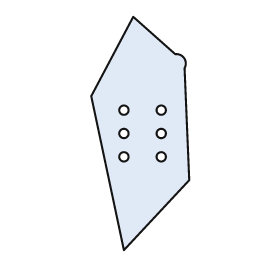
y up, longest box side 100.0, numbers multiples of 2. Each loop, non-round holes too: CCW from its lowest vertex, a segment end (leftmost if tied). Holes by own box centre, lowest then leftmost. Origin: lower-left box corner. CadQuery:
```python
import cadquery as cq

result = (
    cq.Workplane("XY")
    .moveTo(14.0, 0.0)
    .lineTo(42.0, 30.0)
    .lineTo(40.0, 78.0)
    .threePointArc((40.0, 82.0), (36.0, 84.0))
    .lineTo(18.0, 100.0)
    .lineTo(0.0, 66.0)
    .close()
    .moveTo(14.0, 40.0)
    .circle(2.0)
    .moveTo(30.0, 40.0)
    .circle(2.0)
    .moveTo(14.0, 50.0)
    .circle(2.0)
    .moveTo(30.0, 50.0)
    .circle(2.0)
    .moveTo(14.0, 60.0)
    .circle(2.0)
    .moveTo(30.0, 60.0)
    .circle(2.0)
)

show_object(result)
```